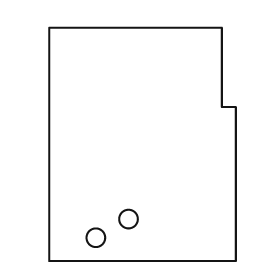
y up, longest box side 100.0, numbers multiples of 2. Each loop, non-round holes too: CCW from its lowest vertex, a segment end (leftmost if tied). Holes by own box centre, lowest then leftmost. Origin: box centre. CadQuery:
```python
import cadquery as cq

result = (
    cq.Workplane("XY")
    .moveTo(-40.0, -50.0)
    .lineTo(40.0, -50.0)
    .lineTo(40.0, 16.0)
    .lineTo(34.0, 16.0)
    .lineTo(34.0, 50.0)
    .lineTo(-40.0, 50.0)
    .close()
    .moveTo(-20.0, -40.0)
    .circle(4.0)
    .moveTo(-6.0, -32.0)
    .circle(4.0)
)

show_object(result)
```